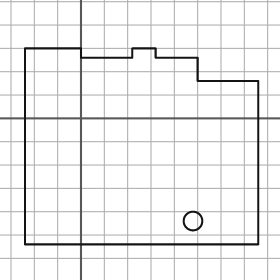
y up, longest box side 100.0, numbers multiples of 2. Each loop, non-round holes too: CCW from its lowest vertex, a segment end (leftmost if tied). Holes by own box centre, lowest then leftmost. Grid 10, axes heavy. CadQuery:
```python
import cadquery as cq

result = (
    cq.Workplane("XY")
    .moveTo(-24.0, -54.0)
    .lineTo(76.0, -54.0)
    .lineTo(76.0, 16.0)
    .lineTo(50.0, 16.0)
    .lineTo(50.0, 26.0)
    .lineTo(32.0, 26.0)
    .lineTo(32.0, 30.0)
    .lineTo(22.0, 30.0)
    .lineTo(22.0, 26.0)
    .lineTo(0.0, 26.0)
    .lineTo(0.0, 30.0)
    .lineTo(-24.0, 30.0)
    .close()
    .moveTo(48.0, -44.0)
    .circle(4.0)
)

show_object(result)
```